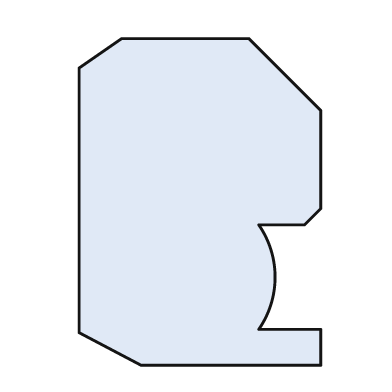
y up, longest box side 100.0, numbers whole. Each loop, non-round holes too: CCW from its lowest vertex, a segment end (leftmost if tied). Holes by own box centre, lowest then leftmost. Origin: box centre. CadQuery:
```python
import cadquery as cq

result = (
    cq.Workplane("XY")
    .moveTo(-18.0, -50.0)
    .lineTo(37.0, -50.0)
    .lineTo(37.0, -39.0)
    .lineTo(18.0, -39.0)
    .threePointArc((23.0, -23.0), (18.0, -7.0))
    .lineTo(32.0, -7.0)
    .lineTo(37.0, -2.0)
    .lineTo(37.0, 28.0)
    .lineTo(15.0, 50.0)
    .lineTo(-24.0, 50.0)
    .lineTo(-37.0, 41.0)
    .lineTo(-37.0, -40.0)
    .close()
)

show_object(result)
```